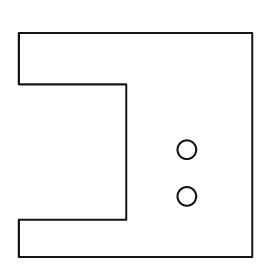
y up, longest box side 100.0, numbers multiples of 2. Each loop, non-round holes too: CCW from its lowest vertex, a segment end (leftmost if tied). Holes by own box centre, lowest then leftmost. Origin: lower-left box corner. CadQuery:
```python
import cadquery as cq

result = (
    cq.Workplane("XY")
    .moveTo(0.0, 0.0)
    .lineTo(100.0, 0.0)
    .lineTo(100.0, 96.0)
    .lineTo(0.0, 96.0)
    .lineTo(0.0, 74.0)
    .lineTo(46.0, 74.0)
    .lineTo(46.0, 16.0)
    .lineTo(0.0, 16.0)
    .close()
    .moveTo(72.0, 26.0)
    .circle(4.0)
    .moveTo(72.0, 46.0)
    .circle(4.0)
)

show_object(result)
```